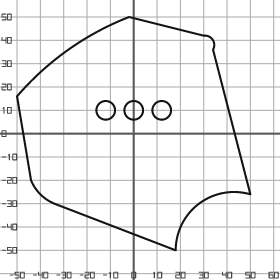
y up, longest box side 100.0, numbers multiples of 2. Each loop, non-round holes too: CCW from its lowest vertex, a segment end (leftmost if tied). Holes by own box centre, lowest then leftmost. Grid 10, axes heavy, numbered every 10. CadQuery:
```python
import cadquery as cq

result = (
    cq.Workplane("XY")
    .moveTo(18.0, -50.0)
    .threePointArc((28.0, -30.0), (50.0, -26.0))
    .lineTo(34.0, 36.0)
    .threePointArc((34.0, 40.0), (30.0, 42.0))
    .lineTo(-2.0, 50.0)
    .threePointArc((-28.0, 36.0), (-50.0, 16.0))
    .lineTo(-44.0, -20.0)
    .threePointArc((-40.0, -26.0), (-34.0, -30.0))
    .close()
    .moveTo(-12.0, 10.0)
    .circle(4.0)
    .moveTo(0.0, 10.0)
    .circle(4.0)
    .moveTo(12.0, 10.0)
    .circle(4.0)
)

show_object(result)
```